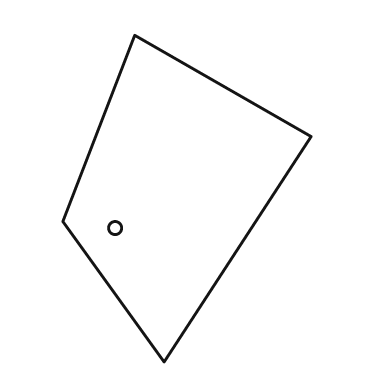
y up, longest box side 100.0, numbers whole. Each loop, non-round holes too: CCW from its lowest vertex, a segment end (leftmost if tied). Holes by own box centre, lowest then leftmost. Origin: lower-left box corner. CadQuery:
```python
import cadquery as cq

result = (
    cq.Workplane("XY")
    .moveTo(31.0, 0.0)
    .lineTo(76.0, 69.0)
    .lineTo(22.0, 100.0)
    .lineTo(0.0, 43.0)
    .close()
    .moveTo(16.0, 41.0)
    .circle(2.0)
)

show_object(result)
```